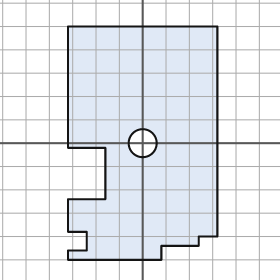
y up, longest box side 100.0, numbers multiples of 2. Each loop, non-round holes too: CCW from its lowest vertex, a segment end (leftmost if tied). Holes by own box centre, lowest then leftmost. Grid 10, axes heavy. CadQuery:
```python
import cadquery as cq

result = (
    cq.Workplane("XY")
    .moveTo(-32.0, -50.0)
    .lineTo(8.0, -50.0)
    .lineTo(8.0, -44.0)
    .lineTo(24.0, -44.0)
    .lineTo(24.0, -40.0)
    .lineTo(32.0, -40.0)
    .lineTo(32.0, 50.0)
    .lineTo(-32.0, 50.0)
    .lineTo(-32.0, -2.0)
    .lineTo(-16.0, -2.0)
    .lineTo(-16.0, -24.0)
    .lineTo(-32.0, -24.0)
    .lineTo(-32.0, -38.0)
    .lineTo(-24.0, -38.0)
    .lineTo(-24.0, -46.0)
    .lineTo(-32.0, -46.0)
    .close()
    .moveTo(0.0, 0.0)
    .circle(6.0)
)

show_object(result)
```